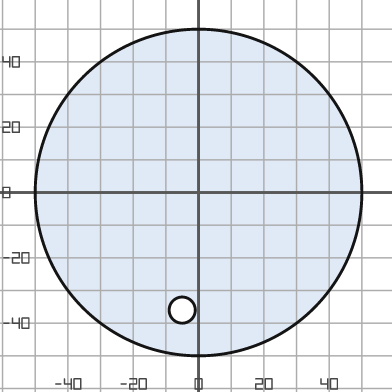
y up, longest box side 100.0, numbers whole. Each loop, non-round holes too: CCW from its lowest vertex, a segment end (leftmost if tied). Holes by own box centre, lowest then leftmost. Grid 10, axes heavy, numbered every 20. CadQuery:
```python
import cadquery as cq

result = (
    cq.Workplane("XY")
    .moveTo(0.0, 0.0)
    .circle(50.0)
    .moveTo(-5.0, -36.0)
    .circle(4.0)
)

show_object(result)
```